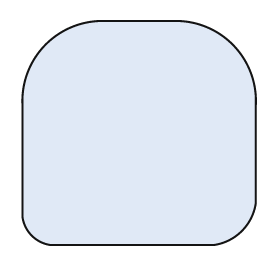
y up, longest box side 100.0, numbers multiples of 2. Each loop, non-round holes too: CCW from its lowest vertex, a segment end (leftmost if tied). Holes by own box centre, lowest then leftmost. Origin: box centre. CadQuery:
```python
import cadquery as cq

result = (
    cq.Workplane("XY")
    .moveTo(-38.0, -48.0)
    .lineTo(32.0, -48.0)
    .threePointArc((44.0, -42.0), (50.0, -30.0))
    .lineTo(50.0, 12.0)
    .threePointArc((40.0, 38.0), (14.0, 48.0))
    .lineTo(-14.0, 48.0)
    .threePointArc((-40.0, 38.0), (-50.0, 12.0))
    .lineTo(-50.0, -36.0)
    .threePointArc((-46.0, -44.0), (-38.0, -48.0))
    .close()
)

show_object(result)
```